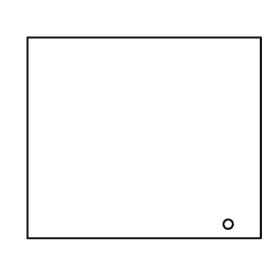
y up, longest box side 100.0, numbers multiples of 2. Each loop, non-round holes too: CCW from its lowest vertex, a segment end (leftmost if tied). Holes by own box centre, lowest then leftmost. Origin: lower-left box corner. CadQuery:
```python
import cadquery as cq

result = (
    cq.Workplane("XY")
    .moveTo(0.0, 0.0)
    .lineTo(100.0, 0.0)
    .lineTo(100.0, 86.0)
    .lineTo(0.0, 86.0)
    .close()
    .moveTo(86.0, 6.0)
    .circle(2.0)
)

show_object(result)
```